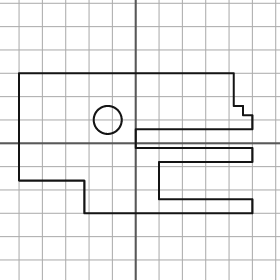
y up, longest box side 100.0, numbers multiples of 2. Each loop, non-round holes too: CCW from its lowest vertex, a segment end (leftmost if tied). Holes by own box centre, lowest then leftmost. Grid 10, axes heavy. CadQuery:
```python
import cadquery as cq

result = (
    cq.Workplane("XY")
    .moveTo(-22.0, -30.0)
    .lineTo(50.0, -30.0)
    .lineTo(50.0, -24.0)
    .lineTo(10.0, -24.0)
    .lineTo(10.0, -8.0)
    .lineTo(50.0, -8.0)
    .lineTo(50.0, -2.0)
    .lineTo(0.0, -2.0)
    .lineTo(0.0, 6.0)
    .lineTo(50.0, 6.0)
    .lineTo(50.0, 12.0)
    .lineTo(46.0, 12.0)
    .lineTo(46.0, 16.0)
    .lineTo(42.0, 16.0)
    .lineTo(42.0, 30.0)
    .lineTo(-50.0, 30.0)
    .lineTo(-50.0, -16.0)
    .lineTo(-22.0, -16.0)
    .close()
    .moveTo(-12.0, 10.0)
    .circle(6.0)
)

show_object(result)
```